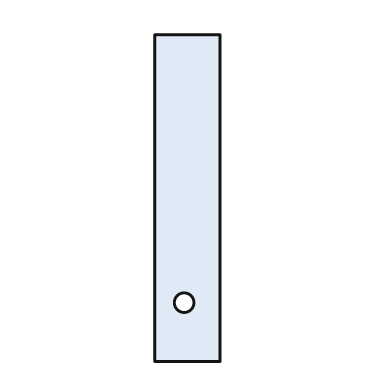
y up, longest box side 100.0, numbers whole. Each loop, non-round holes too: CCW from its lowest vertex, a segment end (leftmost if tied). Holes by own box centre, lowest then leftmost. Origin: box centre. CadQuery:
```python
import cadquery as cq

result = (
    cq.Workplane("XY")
    .moveTo(-10.0, -50.0)
    .lineTo(10.0, -50.0)
    .lineTo(10.0, 50.0)
    .lineTo(-10.0, 50.0)
    .close()
    .moveTo(-1.0, -32.0)
    .circle(3.0)
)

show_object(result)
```